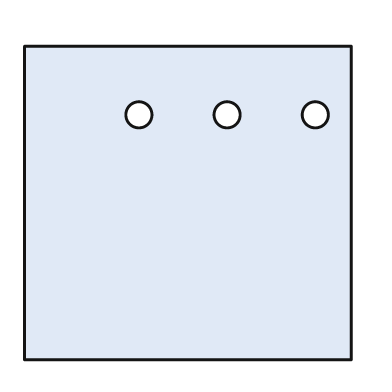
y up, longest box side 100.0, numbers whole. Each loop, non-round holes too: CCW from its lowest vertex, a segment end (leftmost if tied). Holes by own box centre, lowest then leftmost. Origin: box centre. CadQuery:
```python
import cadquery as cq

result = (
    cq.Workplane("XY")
    .moveTo(-50.0, -48.0)
    .lineTo(50.0, -48.0)
    .lineTo(50.0, 48.0)
    .lineTo(-50.0, 48.0)
    .close()
    .moveTo(-15.0, 27.0)
    .circle(4.0)
    .moveTo(12.0, 27.0)
    .circle(4.0)
    .moveTo(39.0, 27.0)
    .circle(4.0)
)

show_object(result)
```